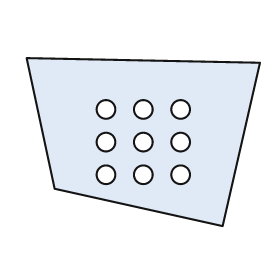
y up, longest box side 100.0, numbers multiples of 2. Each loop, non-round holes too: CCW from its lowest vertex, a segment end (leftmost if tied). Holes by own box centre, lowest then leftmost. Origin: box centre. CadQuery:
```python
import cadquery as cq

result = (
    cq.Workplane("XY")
    .moveTo(34.0, -36.0)
    .lineTo(50.0, 34.0)
    .lineTo(-50.0, 36.0)
    .lineTo(-38.0, -20.0)
    .close()
    .moveTo(-16.0, -14.0)
    .circle(4.0)
    .moveTo(0.0, -14.0)
    .circle(4.0)
    .moveTo(16.0, -14.0)
    .circle(4.0)
    .moveTo(-16.0, 0.0)
    .circle(4.0)
    .moveTo(0.0, 0.0)
    .circle(4.0)
    .moveTo(16.0, 0.0)
    .circle(4.0)
    .moveTo(-16.0, 14.0)
    .circle(4.0)
    .moveTo(0.0, 14.0)
    .circle(4.0)
    .moveTo(16.0, 14.0)
    .circle(4.0)
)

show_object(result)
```